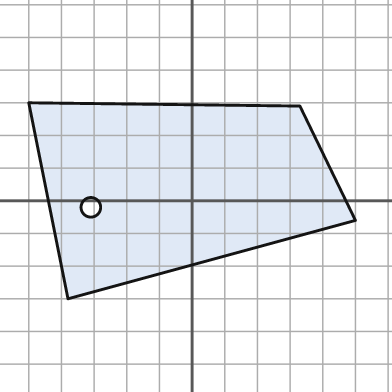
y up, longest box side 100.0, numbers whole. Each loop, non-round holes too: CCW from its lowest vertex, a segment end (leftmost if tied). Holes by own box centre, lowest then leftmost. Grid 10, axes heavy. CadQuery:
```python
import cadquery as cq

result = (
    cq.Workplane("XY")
    .moveTo(-38.0, -30.0)
    .lineTo(50.0, -6.0)
    .lineTo(33.0, 29.0)
    .lineTo(-50.0, 30.0)
    .close()
    .moveTo(-31.0, -2.0)
    .circle(3.0)
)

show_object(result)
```